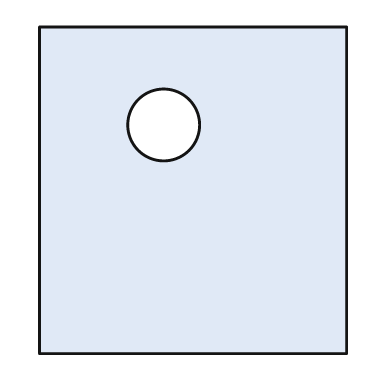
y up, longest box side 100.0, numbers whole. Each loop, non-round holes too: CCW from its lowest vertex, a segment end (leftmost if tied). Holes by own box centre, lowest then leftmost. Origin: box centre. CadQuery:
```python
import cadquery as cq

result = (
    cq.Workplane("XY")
    .moveTo(-47.0, -50.0)
    .lineTo(47.0, -50.0)
    .lineTo(47.0, 50.0)
    .lineTo(-47.0, 50.0)
    .close()
    .moveTo(-9.0, 20.0)
    .circle(11.0)
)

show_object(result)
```